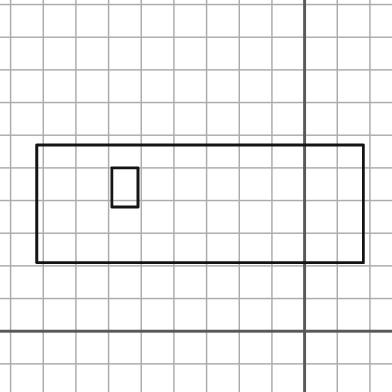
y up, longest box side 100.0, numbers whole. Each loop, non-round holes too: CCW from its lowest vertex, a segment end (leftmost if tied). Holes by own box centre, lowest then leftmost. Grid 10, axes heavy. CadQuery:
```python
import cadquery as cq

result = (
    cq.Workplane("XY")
    .moveTo(-82.0, 21.0)
    .lineTo(18.0, 21.0)
    .lineTo(18.0, 57.0)
    .lineTo(-82.0, 57.0)
    .close()
    .moveTo(-59.0, 38.0)
    .lineTo(-51.0, 38.0)
    .lineTo(-51.0, 50.0)
    .lineTo(-59.0, 50.0)
    .close()
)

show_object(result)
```